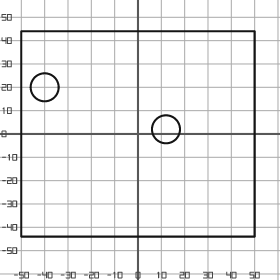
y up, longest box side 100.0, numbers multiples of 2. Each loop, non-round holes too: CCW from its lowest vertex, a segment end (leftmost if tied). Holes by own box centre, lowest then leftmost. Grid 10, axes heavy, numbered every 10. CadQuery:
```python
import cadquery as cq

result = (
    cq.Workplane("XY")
    .moveTo(-50.0, -44.0)
    .lineTo(50.0, -44.0)
    .lineTo(50.0, 44.0)
    .lineTo(-50.0, 44.0)
    .close()
    .moveTo(12.0, 2.0)
    .circle(6.0)
    .moveTo(-40.0, 20.0)
    .circle(6.0)
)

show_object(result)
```